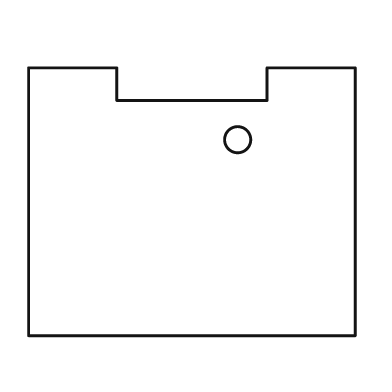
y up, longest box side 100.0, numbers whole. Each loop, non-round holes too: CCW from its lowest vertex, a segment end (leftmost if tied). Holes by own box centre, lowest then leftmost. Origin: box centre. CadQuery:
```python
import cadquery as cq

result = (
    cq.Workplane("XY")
    .moveTo(-50.0, -41.0)
    .lineTo(50.0, -41.0)
    .lineTo(50.0, 41.0)
    .lineTo(23.0, 41.0)
    .lineTo(23.0, 31.0)
    .lineTo(-23.0, 31.0)
    .lineTo(-23.0, 41.0)
    .lineTo(-50.0, 41.0)
    .close()
    .moveTo(14.0, 19.0)
    .circle(4.0)
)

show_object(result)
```